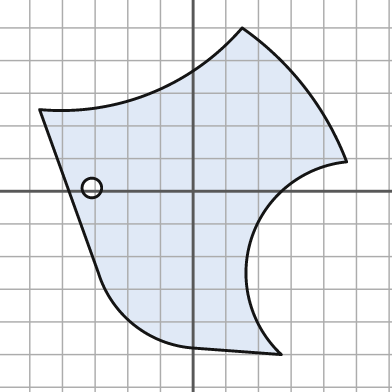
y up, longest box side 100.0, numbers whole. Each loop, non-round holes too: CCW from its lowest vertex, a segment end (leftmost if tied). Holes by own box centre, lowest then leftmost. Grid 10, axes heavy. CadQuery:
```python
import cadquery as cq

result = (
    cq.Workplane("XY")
    .moveTo(27.0, -50.0)
    .threePointArc((18.0, -14.0), (47.0, 9.0))
    .threePointArc((34.0, 32.0), (15.0, 50.0))
    .threePointArc((-13.0, 30.0), (-47.0, 25.0))
    .lineTo(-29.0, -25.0)
    .threePointArc((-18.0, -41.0), (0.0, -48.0))
    .close()
    .moveTo(-31.0, 1.0)
    .circle(3.0)
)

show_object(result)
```